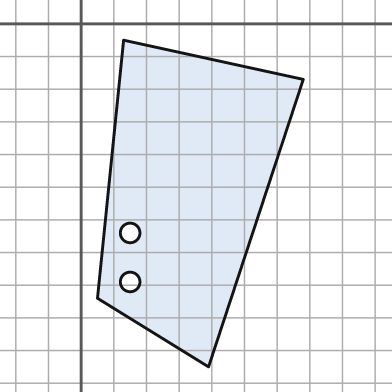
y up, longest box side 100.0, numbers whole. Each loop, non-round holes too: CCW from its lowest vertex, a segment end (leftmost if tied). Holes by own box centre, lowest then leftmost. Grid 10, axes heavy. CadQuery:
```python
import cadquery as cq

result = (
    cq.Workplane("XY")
    .moveTo(39.0, -105.0)
    .lineTo(68.0, -17.0)
    .lineTo(13.0, -5.0)
    .lineTo(5.0, -84.0)
    .close()
    .moveTo(15.0, -79.0)
    .circle(3.0)
    .moveTo(15.0, -64.0)
    .circle(3.0)
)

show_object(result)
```